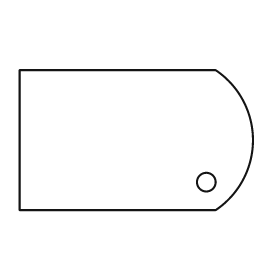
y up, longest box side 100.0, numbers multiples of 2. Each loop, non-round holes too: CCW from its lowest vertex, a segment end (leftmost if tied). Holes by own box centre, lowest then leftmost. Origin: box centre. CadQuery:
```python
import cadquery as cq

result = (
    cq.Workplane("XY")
    .moveTo(-50.0, -30.0)
    .lineTo(34.0, -30.0)
    .threePointArc((50.0, 0.0), (34.0, 30.0))
    .lineTo(-50.0, 30.0)
    .close()
    .moveTo(30.0, -18.0)
    .circle(4.0)
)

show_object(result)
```